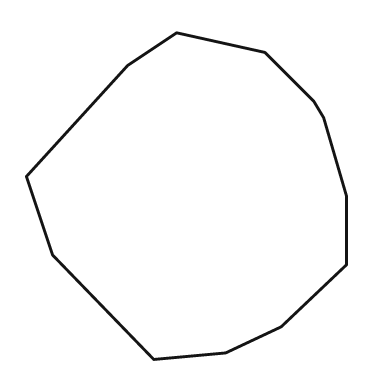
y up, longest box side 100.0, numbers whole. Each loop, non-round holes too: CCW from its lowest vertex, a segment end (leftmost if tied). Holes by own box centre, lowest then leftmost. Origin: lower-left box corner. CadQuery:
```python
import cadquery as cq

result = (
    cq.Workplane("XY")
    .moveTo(39.0, 0.0)
    .lineTo(61.0, 2.0)
    .lineTo(78.0, 10.0)
    .lineTo(98.0, 29.0)
    .lineTo(98.0, 50.0)
    .lineTo(91.0, 74.0)
    .lineTo(88.0, 79.0)
    .lineTo(73.0, 94.0)
    .lineTo(46.0, 100.0)
    .lineTo(31.0, 90.0)
    .lineTo(0.0, 56.0)
    .lineTo(8.0, 32.0)
    .close()
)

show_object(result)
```